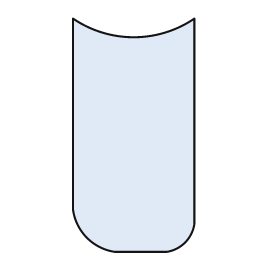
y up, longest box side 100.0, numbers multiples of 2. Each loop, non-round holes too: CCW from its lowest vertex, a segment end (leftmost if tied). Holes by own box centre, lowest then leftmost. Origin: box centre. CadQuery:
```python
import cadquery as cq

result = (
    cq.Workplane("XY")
    .moveTo(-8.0, -50.0)
    .lineTo(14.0, -50.0)
    .threePointArc((22.0, -46.0), (26.0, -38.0))
    .lineTo(26.0, 50.0)
    .threePointArc((0.0, 42.0), (-26.0, 50.0))
    .lineTo(-26.0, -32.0)
    .threePointArc((-20.0, -44.0), (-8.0, -50.0))
    .close()
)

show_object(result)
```